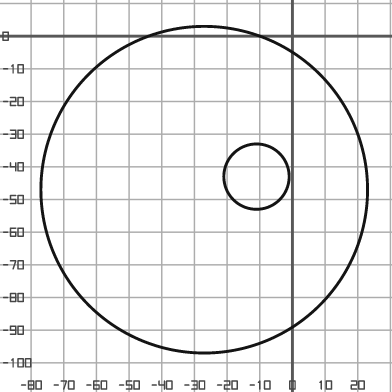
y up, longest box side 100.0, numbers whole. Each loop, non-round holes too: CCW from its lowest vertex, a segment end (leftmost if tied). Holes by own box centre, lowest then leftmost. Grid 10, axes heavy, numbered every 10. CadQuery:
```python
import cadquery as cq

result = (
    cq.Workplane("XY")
    .moveTo(-27.0, -47.0)
    .circle(50.0)
    .moveTo(-11.0, -43.0)
    .circle(10.0)
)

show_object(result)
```